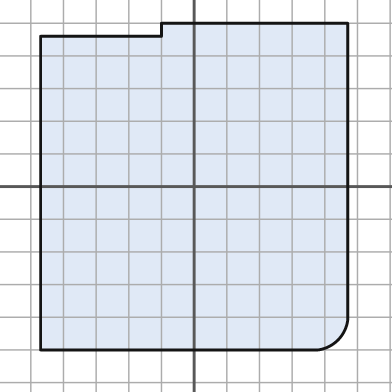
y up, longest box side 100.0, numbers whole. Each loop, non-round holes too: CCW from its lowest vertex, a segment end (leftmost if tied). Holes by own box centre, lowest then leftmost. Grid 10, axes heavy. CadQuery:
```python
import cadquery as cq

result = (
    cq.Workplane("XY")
    .moveTo(-47.0, -50.0)
    .lineTo(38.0, -50.0)
    .threePointArc((44.0, -47.0), (47.0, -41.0))
    .lineTo(47.0, 50.0)
    .lineTo(-10.0, 50.0)
    .lineTo(-10.0, 46.0)
    .lineTo(-47.0, 46.0)
    .close()
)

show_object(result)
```